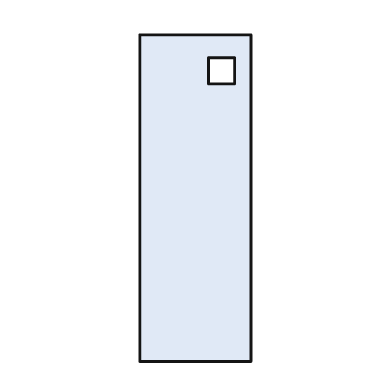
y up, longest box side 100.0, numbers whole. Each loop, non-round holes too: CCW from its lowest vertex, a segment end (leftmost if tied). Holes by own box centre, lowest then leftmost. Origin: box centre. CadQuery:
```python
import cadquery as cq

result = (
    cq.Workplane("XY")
    .moveTo(-17.0, -50.0)
    .lineTo(17.0, -50.0)
    .lineTo(17.0, 50.0)
    .lineTo(-17.0, 50.0)
    .close()
    .moveTo(4.0, 35.0)
    .lineTo(12.0, 35.0)
    .lineTo(12.0, 43.0)
    .lineTo(4.0, 43.0)
    .close()
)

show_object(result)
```